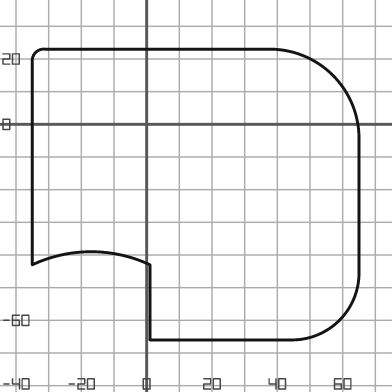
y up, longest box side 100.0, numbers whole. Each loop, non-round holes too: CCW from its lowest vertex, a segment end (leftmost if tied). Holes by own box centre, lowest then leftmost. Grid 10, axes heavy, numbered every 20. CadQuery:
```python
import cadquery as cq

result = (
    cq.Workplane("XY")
    .moveTo(1.0, -66.0)
    .lineTo(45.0, -66.0)
    .threePointArc((59.0, -60.0), (65.0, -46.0))
    .lineTo(65.0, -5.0)
    .threePointArc((57.0, 15.0), (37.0, 23.0))
    .lineTo(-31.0, 23.0)
    .threePointArc((-34.0, 22.0), (-35.0, 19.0))
    .lineTo(-35.0, -43.0)
    .threePointArc((-17.0, -39.0), (1.0, -43.0))
    .close()
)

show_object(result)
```